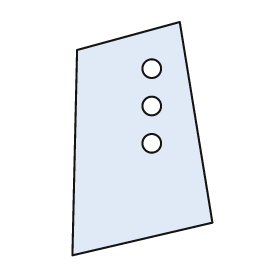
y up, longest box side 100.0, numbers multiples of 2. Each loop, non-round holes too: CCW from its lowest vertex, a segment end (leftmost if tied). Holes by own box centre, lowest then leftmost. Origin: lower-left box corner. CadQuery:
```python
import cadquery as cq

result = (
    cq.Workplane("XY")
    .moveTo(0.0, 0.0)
    .lineTo(60.0, 14.0)
    .lineTo(46.0, 100.0)
    .lineTo(2.0, 88.0)
    .close()
    .moveTo(34.0, 48.0)
    .circle(4.0)
    .moveTo(34.0, 64.0)
    .circle(4.0)
    .moveTo(34.0, 80.0)
    .circle(4.0)
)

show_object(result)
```